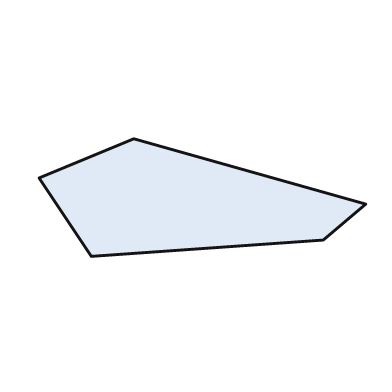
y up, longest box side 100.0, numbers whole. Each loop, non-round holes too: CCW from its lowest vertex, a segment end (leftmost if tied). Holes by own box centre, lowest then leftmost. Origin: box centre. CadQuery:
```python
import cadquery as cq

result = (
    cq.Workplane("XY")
    .moveTo(-34.0, -18.0)
    .lineTo(37.0, -13.0)
    .lineTo(50.0, -2.0)
    .lineTo(-21.0, 18.0)
    .lineTo(-50.0, 6.0)
    .close()
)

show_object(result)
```